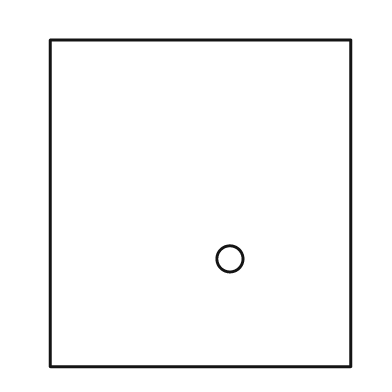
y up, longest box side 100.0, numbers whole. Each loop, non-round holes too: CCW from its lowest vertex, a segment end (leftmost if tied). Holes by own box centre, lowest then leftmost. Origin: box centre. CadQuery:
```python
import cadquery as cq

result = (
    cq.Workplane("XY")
    .moveTo(-46.0, -50.0)
    .lineTo(46.0, -50.0)
    .lineTo(46.0, 50.0)
    .lineTo(-46.0, 50.0)
    .close()
    .moveTo(9.0, -17.0)
    .circle(4.0)
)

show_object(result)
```